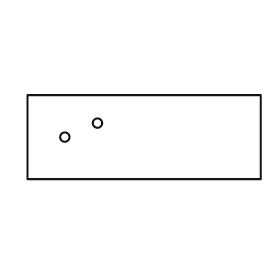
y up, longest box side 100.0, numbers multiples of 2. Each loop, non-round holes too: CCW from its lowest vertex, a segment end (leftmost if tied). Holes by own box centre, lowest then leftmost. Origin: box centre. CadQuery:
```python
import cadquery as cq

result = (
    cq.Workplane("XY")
    .moveTo(-50.0, -18.0)
    .lineTo(50.0, -18.0)
    .lineTo(50.0, 18.0)
    .lineTo(-50.0, 18.0)
    .close()
    .moveTo(-34.0, 0.0)
    .circle(2.0)
    .moveTo(-20.0, 6.0)
    .circle(2.0)
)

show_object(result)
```